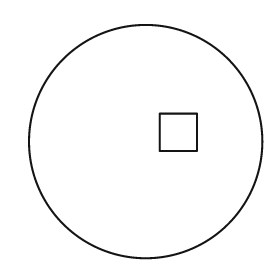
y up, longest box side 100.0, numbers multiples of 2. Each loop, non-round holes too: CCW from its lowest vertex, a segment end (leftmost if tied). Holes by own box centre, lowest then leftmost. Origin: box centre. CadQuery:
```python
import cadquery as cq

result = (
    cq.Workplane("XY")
    .moveTo(0.0, 0.0)
    .circle(50.0)
    .moveTo(6.0, -4.0)
    .lineTo(22.0, -4.0)
    .lineTo(22.0, 12.0)
    .lineTo(6.0, 12.0)
    .close()
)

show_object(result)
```